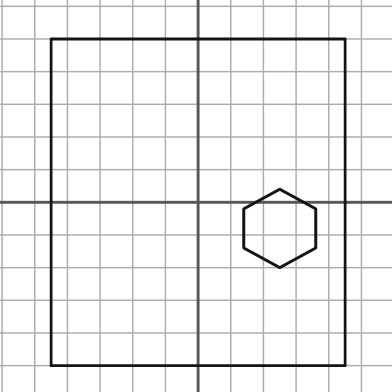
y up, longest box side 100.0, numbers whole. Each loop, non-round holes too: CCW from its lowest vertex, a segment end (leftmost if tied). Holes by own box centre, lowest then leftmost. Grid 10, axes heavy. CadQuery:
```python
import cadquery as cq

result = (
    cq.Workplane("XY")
    .moveTo(-45.0, -50.0)
    .lineTo(45.0, -50.0)
    .lineTo(45.0, 50.0)
    .lineTo(-45.0, 50.0)
    .close()
    .moveTo(25.0, -20.0)
    .lineTo(36.0, -14.0)
    .lineTo(36.0, -2.0)
    .lineTo(25.0, 4.0)
    .lineTo(14.0, -2.0)
    .lineTo(14.0, -14.0)
    .close()
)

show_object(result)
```